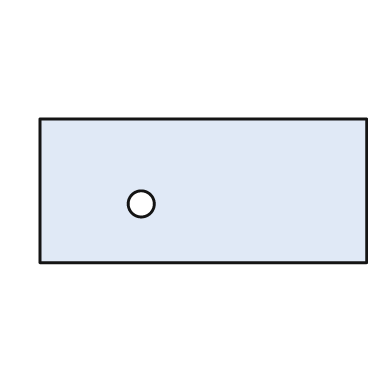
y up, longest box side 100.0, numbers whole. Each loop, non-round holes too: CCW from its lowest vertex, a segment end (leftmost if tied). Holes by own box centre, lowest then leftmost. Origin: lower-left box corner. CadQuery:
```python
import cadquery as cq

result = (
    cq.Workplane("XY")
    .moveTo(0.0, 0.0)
    .lineTo(100.0, 0.0)
    .lineTo(100.0, 44.0)
    .lineTo(0.0, 44.0)
    .close()
    .moveTo(31.0, 18.0)
    .circle(4.0)
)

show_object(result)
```